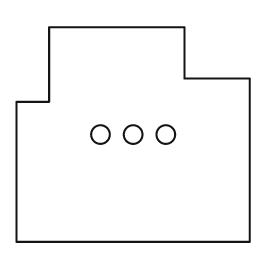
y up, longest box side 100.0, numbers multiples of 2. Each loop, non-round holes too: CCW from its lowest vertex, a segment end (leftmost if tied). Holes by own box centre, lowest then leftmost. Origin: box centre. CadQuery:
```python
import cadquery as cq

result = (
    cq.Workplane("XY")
    .moveTo(-50.0, -46.0)
    .lineTo(50.0, -46.0)
    .lineTo(50.0, 24.0)
    .lineTo(22.0, 24.0)
    .lineTo(22.0, 46.0)
    .lineTo(-36.0, 46.0)
    .lineTo(-36.0, 14.0)
    .lineTo(-50.0, 14.0)
    .close()
    .moveTo(-14.0, 0.0)
    .circle(4.0)
    .moveTo(0.0, 0.0)
    .circle(4.0)
    .moveTo(14.0, 0.0)
    .circle(4.0)
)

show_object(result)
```